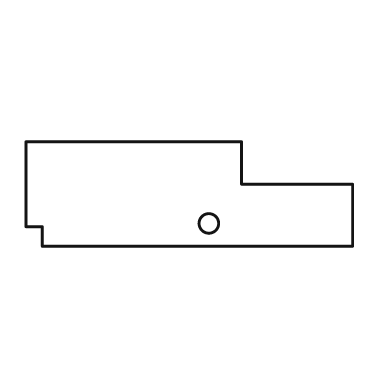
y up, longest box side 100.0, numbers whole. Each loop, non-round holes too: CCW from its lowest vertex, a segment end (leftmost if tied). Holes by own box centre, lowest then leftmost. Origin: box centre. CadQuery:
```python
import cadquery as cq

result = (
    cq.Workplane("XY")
    .moveTo(-45.0, -16.0)
    .lineTo(50.0, -16.0)
    .lineTo(50.0, 3.0)
    .lineTo(16.0, 3.0)
    .lineTo(16.0, 16.0)
    .lineTo(-50.0, 16.0)
    .lineTo(-50.0, -10.0)
    .lineTo(-45.0, -10.0)
    .close()
    .moveTo(6.0, -9.0)
    .circle(3.0)
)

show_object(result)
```